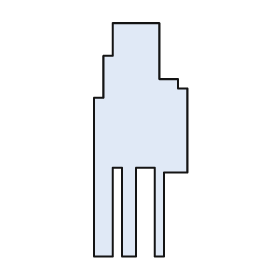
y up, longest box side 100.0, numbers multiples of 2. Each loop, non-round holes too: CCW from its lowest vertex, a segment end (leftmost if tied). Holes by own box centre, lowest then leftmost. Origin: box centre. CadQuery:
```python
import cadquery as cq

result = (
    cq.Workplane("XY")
    .moveTo(-20.0, -50.0)
    .lineTo(-12.0, -50.0)
    .lineTo(-12.0, -12.0)
    .lineTo(-8.0, -12.0)
    .lineTo(-8.0, -50.0)
    .lineTo(-2.0, -50.0)
    .lineTo(-2.0, -12.0)
    .lineTo(6.0, -12.0)
    .lineTo(6.0, -50.0)
    .lineTo(10.0, -50.0)
    .lineTo(10.0, -14.0)
    .lineTo(20.0, -14.0)
    .lineTo(20.0, 22.0)
    .lineTo(16.0, 22.0)
    .lineTo(16.0, 26.0)
    .lineTo(8.0, 26.0)
    .lineTo(8.0, 50.0)
    .lineTo(-12.0, 50.0)
    .lineTo(-12.0, 36.0)
    .lineTo(-16.0, 36.0)
    .lineTo(-16.0, 18.0)
    .lineTo(-20.0, 18.0)
    .close()
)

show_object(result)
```